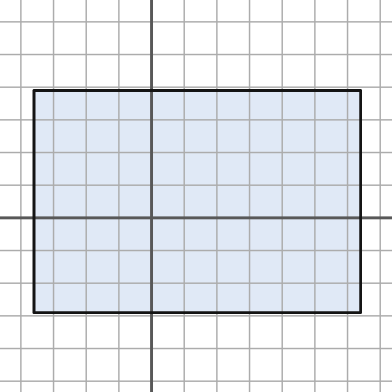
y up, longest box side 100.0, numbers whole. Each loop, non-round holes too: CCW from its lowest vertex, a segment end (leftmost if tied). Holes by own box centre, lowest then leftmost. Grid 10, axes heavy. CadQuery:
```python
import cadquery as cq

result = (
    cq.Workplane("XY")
    .moveTo(-36.0, -29.0)
    .lineTo(64.0, -29.0)
    .lineTo(64.0, 39.0)
    .lineTo(-36.0, 39.0)
    .close()
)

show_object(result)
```